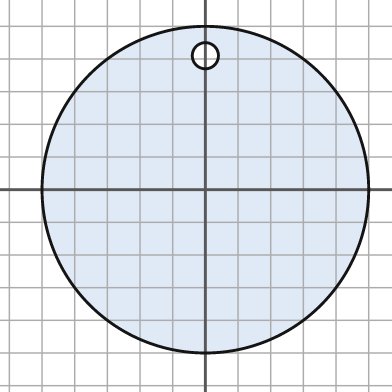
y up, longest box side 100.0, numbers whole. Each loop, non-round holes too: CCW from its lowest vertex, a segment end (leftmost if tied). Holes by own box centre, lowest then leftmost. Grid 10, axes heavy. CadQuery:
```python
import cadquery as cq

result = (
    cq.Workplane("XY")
    .moveTo(0.0, 0.0)
    .circle(50.0)
    .moveTo(0.0, 41.0)
    .circle(4.0)
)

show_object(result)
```